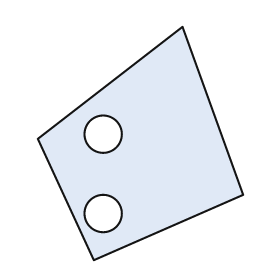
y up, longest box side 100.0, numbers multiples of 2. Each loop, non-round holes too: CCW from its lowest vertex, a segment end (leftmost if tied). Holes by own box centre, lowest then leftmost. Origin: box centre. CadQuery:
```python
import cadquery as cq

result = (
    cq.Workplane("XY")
    .moveTo(-20.0, -50.0)
    .lineTo(44.0, -22.0)
    .lineTo(18.0, 50.0)
    .lineTo(-44.0, 2.0)
    .close()
    .moveTo(-16.0, -30.0)
    .circle(8.0)
    .moveTo(-16.0, 4.0)
    .circle(8.0)
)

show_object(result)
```